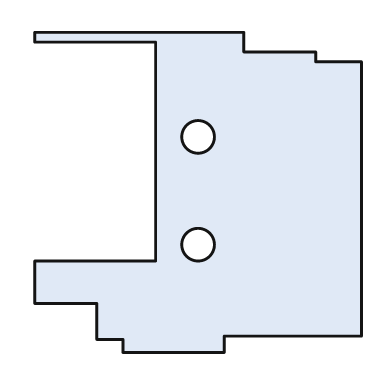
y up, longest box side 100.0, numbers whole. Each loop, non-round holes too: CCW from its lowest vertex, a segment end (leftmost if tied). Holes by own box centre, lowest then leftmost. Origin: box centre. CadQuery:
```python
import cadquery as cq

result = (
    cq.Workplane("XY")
    .moveTo(-23.0, -49.0)
    .lineTo(8.0, -49.0)
    .lineTo(8.0, -44.0)
    .lineTo(50.0, -44.0)
    .lineTo(50.0, 40.0)
    .lineTo(36.0, 40.0)
    .lineTo(36.0, 43.0)
    .lineTo(14.0, 43.0)
    .lineTo(14.0, 49.0)
    .lineTo(-50.0, 49.0)
    .lineTo(-50.0, 46.0)
    .lineTo(-13.0, 46.0)
    .lineTo(-13.0, -21.0)
    .lineTo(-50.0, -21.0)
    .lineTo(-50.0, -34.0)
    .lineTo(-31.0, -34.0)
    .lineTo(-31.0, -45.0)
    .lineTo(-23.0, -45.0)
    .close()
    .moveTo(0.0, -16.0)
    .circle(5.0)
    .moveTo(0.0, 17.0)
    .circle(5.0)
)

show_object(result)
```